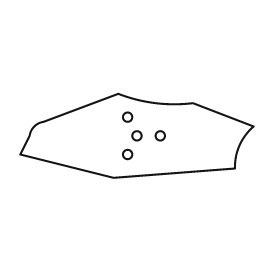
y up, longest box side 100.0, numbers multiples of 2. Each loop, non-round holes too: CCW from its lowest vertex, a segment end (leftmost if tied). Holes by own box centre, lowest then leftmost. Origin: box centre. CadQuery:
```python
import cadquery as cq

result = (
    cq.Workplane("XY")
    .moveTo(-10.0, -18.0)
    .lineTo(42.0, -14.0)
    .threePointArc((44.0, -4.0), (50.0, 4.0))
    .lineTo(24.0, 14.0)
    .threePointArc((8.0, 14.0), (-8.0, 18.0))
    .lineTo(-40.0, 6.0)
    .threePointArc((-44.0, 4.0), (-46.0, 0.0))
    .lineTo(-50.0, -8.0)
    .close()
    .moveTo(-4.0, -8.0)
    .circle(2.0)
    .moveTo(0.0, 0.0)
    .circle(2.0)
    .moveTo(10.0, 0.0)
    .circle(2.0)
    .moveTo(-4.0, 8.0)
    .circle(2.0)
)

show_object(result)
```